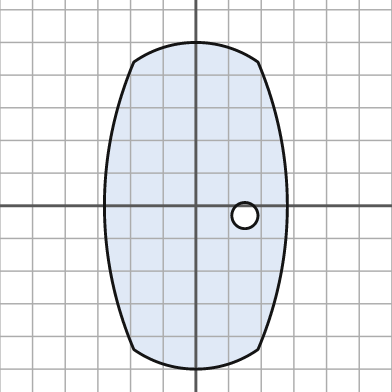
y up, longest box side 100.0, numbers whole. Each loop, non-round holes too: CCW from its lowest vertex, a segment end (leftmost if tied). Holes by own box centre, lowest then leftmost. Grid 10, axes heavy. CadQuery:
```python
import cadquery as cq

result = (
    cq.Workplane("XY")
    .moveTo(-19.0, -44.0)
    .threePointArc((0.0, -50.0), (19.0, -44.0))
    .threePointArc((28.0, 0.0), (19.0, 44.0))
    .threePointArc((0.0, 50.0), (-19.0, 44.0))
    .threePointArc((-28.0, 0.0), (-19.0, -44.0))
    .close()
    .moveTo(15.0, -3.0)
    .circle(4.0)
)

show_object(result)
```